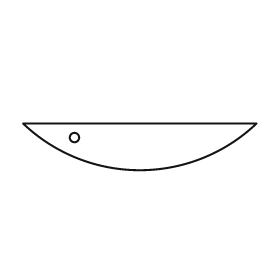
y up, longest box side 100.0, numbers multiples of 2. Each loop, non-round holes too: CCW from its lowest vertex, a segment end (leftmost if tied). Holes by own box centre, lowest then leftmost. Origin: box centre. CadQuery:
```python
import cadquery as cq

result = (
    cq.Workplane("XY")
    .moveTo(-50.0, 10.0)
    .threePointArc((0.0, -10.0), (50.0, 10.0))
    .close()
    .moveTo(-28.0, 4.0)
    .circle(2.0)
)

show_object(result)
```